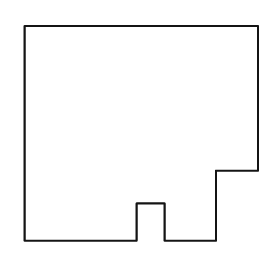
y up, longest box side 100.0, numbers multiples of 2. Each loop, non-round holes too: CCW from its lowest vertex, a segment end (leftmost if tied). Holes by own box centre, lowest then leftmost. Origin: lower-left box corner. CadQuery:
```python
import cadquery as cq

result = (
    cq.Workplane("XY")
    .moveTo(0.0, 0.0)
    .lineTo(48.0, 0.0)
    .lineTo(48.0, 16.0)
    .lineTo(60.0, 16.0)
    .lineTo(60.0, 0.0)
    .lineTo(82.0, 0.0)
    .lineTo(82.0, 30.0)
    .lineTo(100.0, 30.0)
    .lineTo(100.0, 92.0)
    .lineTo(0.0, 92.0)
    .close()
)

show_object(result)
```